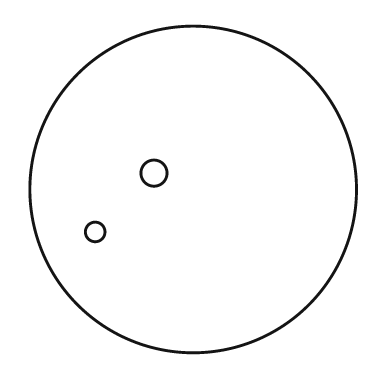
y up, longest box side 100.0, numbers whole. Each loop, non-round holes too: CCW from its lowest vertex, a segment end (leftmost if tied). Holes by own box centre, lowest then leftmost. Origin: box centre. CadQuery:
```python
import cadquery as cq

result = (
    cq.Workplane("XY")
    .moveTo(0.0, 0.0)
    .circle(50.0)
    .moveTo(-30.0, -13.0)
    .circle(3.0)
    .moveTo(-12.0, 5.0)
    .circle(4.0)
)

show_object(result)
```